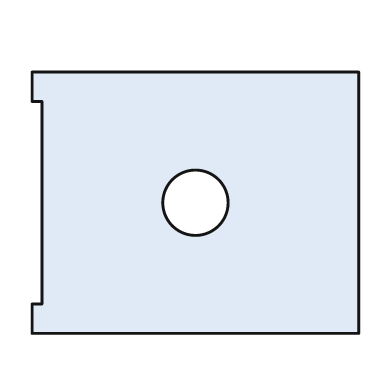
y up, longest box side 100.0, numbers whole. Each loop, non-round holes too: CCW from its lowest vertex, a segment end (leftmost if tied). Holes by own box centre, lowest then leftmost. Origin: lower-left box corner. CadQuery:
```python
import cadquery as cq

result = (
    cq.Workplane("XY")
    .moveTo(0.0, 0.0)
    .lineTo(100.0, 0.0)
    .lineTo(100.0, 80.0)
    .lineTo(0.0, 80.0)
    .lineTo(0.0, 71.0)
    .lineTo(3.0, 71.0)
    .lineTo(3.0, 9.0)
    .lineTo(0.0, 9.0)
    .close()
    .moveTo(50.0, 40.0)
    .circle(10.0)
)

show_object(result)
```